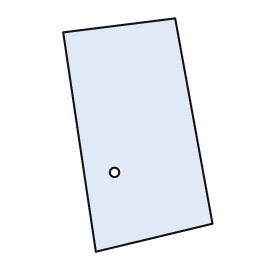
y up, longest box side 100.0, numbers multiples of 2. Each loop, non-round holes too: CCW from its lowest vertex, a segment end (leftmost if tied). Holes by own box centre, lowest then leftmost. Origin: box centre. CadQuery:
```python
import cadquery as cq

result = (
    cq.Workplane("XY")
    .moveTo(-18.0, -50.0)
    .lineTo(32.0, -38.0)
    .lineTo(16.0, 50.0)
    .lineTo(-32.0, 44.0)
    .close()
    .moveTo(-10.0, -16.0)
    .circle(2.0)
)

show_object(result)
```